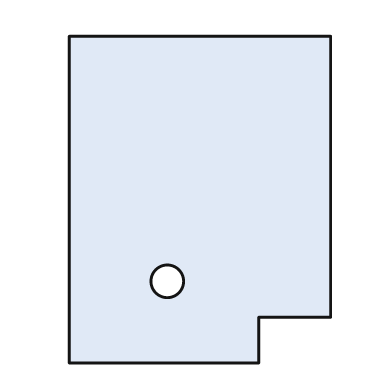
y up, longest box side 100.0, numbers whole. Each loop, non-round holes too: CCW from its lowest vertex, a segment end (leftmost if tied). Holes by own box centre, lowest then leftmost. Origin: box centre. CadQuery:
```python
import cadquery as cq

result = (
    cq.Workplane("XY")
    .moveTo(-40.0, -50.0)
    .lineTo(18.0, -50.0)
    .lineTo(18.0, -36.0)
    .lineTo(40.0, -36.0)
    .lineTo(40.0, 50.0)
    .lineTo(-40.0, 50.0)
    .close()
    .moveTo(-10.0, -25.0)
    .circle(5.0)
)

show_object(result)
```